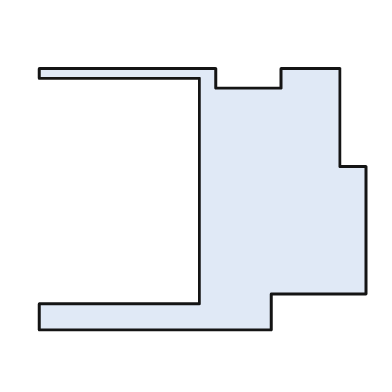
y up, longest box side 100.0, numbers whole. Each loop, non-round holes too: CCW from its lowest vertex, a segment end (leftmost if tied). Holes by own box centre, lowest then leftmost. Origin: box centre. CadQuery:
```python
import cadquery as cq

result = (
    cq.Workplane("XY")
    .moveTo(-50.0, -40.0)
    .lineTo(21.0, -40.0)
    .lineTo(21.0, -29.0)
    .lineTo(50.0, -29.0)
    .lineTo(50.0, 10.0)
    .lineTo(42.0, 10.0)
    .lineTo(42.0, 40.0)
    .lineTo(24.0, 40.0)
    .lineTo(24.0, 34.0)
    .lineTo(4.0, 34.0)
    .lineTo(4.0, 40.0)
    .lineTo(-50.0, 40.0)
    .lineTo(-50.0, 37.0)
    .lineTo(-1.0, 37.0)
    .lineTo(-1.0, -32.0)
    .lineTo(-50.0, -32.0)
    .close()
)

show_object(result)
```